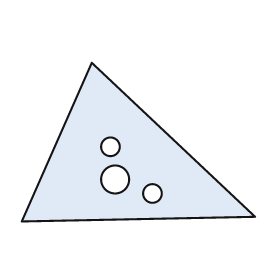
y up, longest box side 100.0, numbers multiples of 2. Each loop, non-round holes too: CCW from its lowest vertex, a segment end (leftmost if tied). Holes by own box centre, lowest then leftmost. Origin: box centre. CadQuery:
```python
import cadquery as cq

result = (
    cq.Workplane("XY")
    .moveTo(-50.0, -34.0)
    .lineTo(50.0, -32.0)
    .lineTo(-20.0, 34.0)
    .close()
    .moveTo(6.0, -22.0)
    .circle(4.0)
    .moveTo(-10.0, -16.0)
    .circle(6.0)
    .moveTo(-12.0, -2.0)
    .circle(4.0)
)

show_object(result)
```